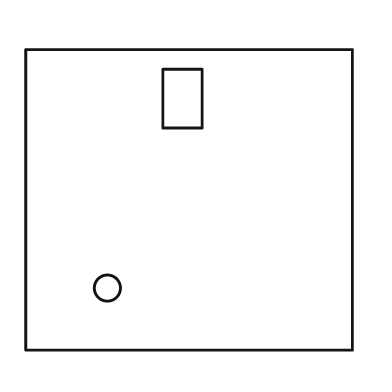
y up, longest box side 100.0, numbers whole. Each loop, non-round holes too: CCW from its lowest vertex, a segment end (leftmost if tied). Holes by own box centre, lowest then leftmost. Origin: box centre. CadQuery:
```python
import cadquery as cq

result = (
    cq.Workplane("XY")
    .moveTo(-50.0, -46.0)
    .lineTo(50.0, -46.0)
    .lineTo(50.0, 46.0)
    .lineTo(-50.0, 46.0)
    .close()
    .moveTo(-25.0, -27.0)
    .circle(4.0)
    .moveTo(-8.0, 22.0)
    .lineTo(4.0, 22.0)
    .lineTo(4.0, 40.0)
    .lineTo(-8.0, 40.0)
    .close()
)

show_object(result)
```